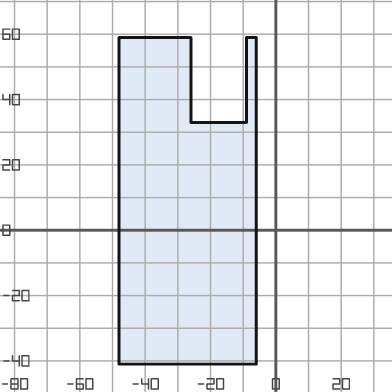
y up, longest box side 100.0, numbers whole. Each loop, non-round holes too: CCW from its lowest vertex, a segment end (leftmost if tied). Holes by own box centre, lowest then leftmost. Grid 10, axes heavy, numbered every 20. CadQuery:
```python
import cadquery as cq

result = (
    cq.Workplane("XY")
    .moveTo(-48.0, -41.0)
    .lineTo(-6.0, -41.0)
    .lineTo(-6.0, 59.0)
    .lineTo(-9.0, 59.0)
    .lineTo(-9.0, 33.0)
    .lineTo(-26.0, 33.0)
    .lineTo(-26.0, 59.0)
    .lineTo(-48.0, 59.0)
    .close()
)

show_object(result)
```